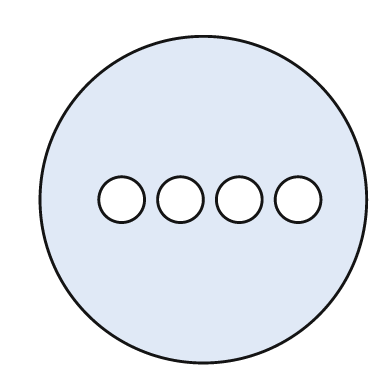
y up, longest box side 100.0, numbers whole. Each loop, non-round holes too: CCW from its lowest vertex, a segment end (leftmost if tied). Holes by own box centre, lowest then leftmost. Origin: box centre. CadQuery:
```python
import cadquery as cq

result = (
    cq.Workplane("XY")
    .moveTo(0.0, 0.0)
    .circle(50.0)
    .moveTo(-25.0, 0.0)
    .circle(7.0)
    .moveTo(-7.0, 0.0)
    .circle(7.0)
    .moveTo(11.0, 0.0)
    .circle(7.0)
    .moveTo(29.0, 0.0)
    .circle(7.0)
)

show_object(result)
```